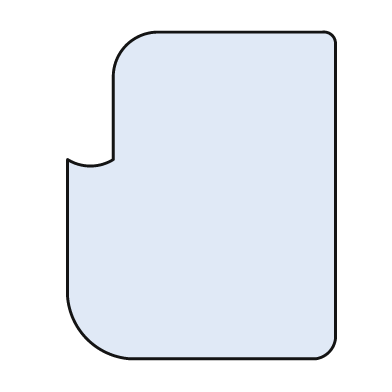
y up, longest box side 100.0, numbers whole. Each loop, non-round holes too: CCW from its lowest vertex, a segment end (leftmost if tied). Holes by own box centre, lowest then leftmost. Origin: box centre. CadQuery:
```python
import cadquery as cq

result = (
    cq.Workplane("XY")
    .moveTo(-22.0, -50.0)
    .lineTo(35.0, -50.0)
    .threePointArc((39.0, -48.0), (41.0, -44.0))
    .lineTo(41.0, 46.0)
    .threePointArc((40.0, 49.0), (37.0, 50.0))
    .lineTo(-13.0, 50.0)
    .threePointArc((-23.0, 46.0), (-27.0, 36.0))
    .lineTo(-27.0, 11.0)
    .threePointArc((-34.0, 9.0), (-41.0, 11.0))
    .lineTo(-41.0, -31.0)
    .threePointArc((-35.0, -44.0), (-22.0, -50.0))
    .close()
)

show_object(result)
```